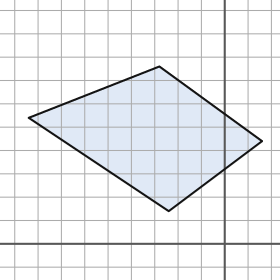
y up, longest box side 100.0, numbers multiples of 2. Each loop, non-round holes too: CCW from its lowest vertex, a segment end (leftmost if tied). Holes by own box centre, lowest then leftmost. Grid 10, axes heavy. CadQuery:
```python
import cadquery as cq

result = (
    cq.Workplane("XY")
    .moveTo(-24.0, 14.0)
    .lineTo(16.0, 44.0)
    .lineTo(-28.0, 76.0)
    .lineTo(-84.0, 54.0)
    .close()
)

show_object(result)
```